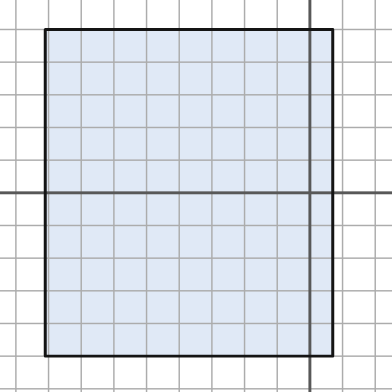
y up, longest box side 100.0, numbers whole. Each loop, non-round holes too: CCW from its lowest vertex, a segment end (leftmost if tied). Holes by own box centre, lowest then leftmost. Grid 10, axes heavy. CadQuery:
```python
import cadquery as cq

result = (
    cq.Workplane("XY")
    .moveTo(-81.0, -50.0)
    .lineTo(7.0, -50.0)
    .lineTo(7.0, 50.0)
    .lineTo(-81.0, 50.0)
    .close()
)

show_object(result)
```